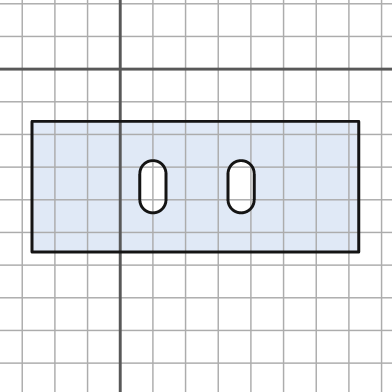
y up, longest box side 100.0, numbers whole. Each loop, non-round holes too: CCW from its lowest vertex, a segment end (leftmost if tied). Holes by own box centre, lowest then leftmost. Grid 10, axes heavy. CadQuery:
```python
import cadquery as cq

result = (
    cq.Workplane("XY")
    .moveTo(-27.0, -56.0)
    .lineTo(73.0, -56.0)
    .lineTo(73.0, -16.0)
    .lineTo(-27.0, -16.0)
    .close()
    .moveTo(6.0, -40.0)
    .threePointArc((10.0, -44.0), (14.0, -40.0))
    .lineTo(14.0, -32.0)
    .threePointArc((10.0, -28.0), (6.0, -32.0))
    .close()
    .moveTo(33.0, -40.0)
    .threePointArc((37.0, -44.0), (41.0, -40.0))
    .lineTo(41.0, -32.0)
    .threePointArc((37.0, -28.0), (33.0, -32.0))
    .close()
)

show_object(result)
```